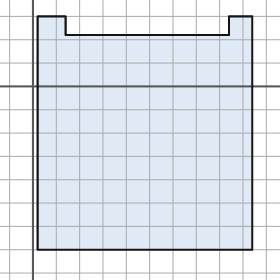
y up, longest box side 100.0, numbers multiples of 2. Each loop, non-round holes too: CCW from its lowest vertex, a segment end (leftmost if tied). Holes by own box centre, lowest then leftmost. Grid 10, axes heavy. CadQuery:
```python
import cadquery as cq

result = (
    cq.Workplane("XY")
    .moveTo(2.0, -70.0)
    .lineTo(94.0, -70.0)
    .lineTo(94.0, 30.0)
    .lineTo(84.0, 30.0)
    .lineTo(84.0, 22.0)
    .lineTo(14.0, 22.0)
    .lineTo(14.0, 30.0)
    .lineTo(2.0, 30.0)
    .close()
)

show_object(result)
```